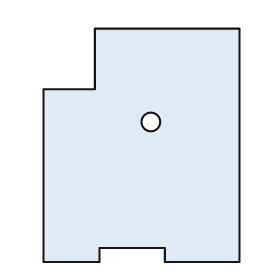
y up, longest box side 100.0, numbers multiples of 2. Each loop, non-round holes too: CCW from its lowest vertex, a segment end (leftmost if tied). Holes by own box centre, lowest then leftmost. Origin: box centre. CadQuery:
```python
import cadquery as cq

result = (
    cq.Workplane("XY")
    .moveTo(-42.0, -50.0)
    .lineTo(-18.0, -50.0)
    .lineTo(-18.0, -44.0)
    .lineTo(10.0, -44.0)
    .lineTo(10.0, -50.0)
    .lineTo(42.0, -50.0)
    .lineTo(42.0, 50.0)
    .lineTo(-20.0, 50.0)
    .lineTo(-20.0, 24.0)
    .lineTo(-42.0, 24.0)
    .close()
    .moveTo(4.0, 10.0)
    .circle(4.0)
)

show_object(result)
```